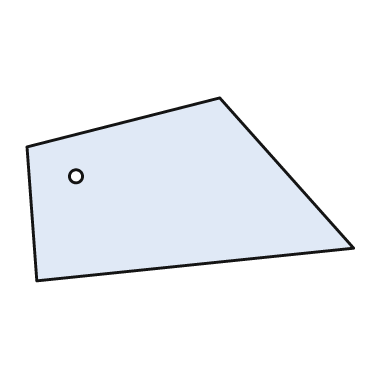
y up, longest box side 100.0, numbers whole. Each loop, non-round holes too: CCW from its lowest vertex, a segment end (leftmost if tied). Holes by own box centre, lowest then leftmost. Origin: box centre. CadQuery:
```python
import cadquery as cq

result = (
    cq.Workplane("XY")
    .moveTo(-47.0, -28.0)
    .lineTo(50.0, -18.0)
    .lineTo(9.0, 28.0)
    .lineTo(-50.0, 13.0)
    .close()
    .moveTo(-35.0, 4.0)
    .circle(2.0)
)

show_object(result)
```